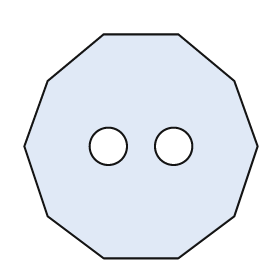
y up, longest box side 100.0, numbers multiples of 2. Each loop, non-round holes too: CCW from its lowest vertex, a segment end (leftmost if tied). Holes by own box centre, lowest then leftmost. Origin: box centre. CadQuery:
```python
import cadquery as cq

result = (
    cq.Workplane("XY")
    .moveTo(-16.0, -48.0)
    .lineTo(16.0, -48.0)
    .lineTo(40.0, -30.0)
    .lineTo(50.0, 0.0)
    .lineTo(40.0, 28.0)
    .lineTo(16.0, 48.0)
    .lineTo(-16.0, 48.0)
    .lineTo(-40.0, 28.0)
    .lineTo(-50.0, 0.0)
    .lineTo(-40.0, -30.0)
    .close()
    .moveTo(-14.0, 0.0)
    .circle(8.0)
    .moveTo(14.0, 0.0)
    .circle(8.0)
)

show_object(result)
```